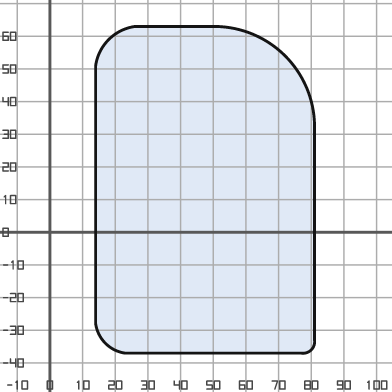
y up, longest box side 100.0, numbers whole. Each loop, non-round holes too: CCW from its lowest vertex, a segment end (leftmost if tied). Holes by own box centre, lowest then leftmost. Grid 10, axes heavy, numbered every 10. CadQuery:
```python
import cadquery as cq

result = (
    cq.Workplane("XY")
    .moveTo(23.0, -37.0)
    .lineTo(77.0, -37.0)
    .threePointArc((80.0, -36.0), (81.0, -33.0))
    .lineTo(81.0, 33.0)
    .threePointArc((72.0, 54.0), (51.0, 63.0))
    .lineTo(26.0, 63.0)
    .threePointArc((18.0, 59.0), (14.0, 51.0))
    .lineTo(14.0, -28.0)
    .threePointArc((17.0, -34.0), (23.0, -37.0))
    .close()
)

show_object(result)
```